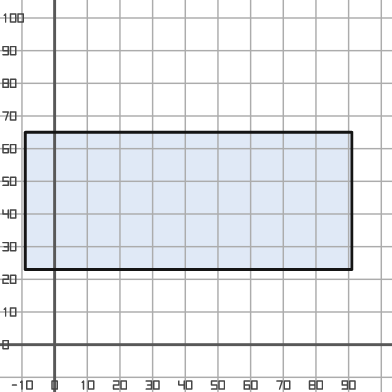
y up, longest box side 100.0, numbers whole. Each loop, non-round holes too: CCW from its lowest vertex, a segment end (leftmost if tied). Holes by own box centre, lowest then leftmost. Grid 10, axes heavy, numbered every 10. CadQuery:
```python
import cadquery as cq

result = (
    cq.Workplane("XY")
    .moveTo(-9.0, 23.0)
    .lineTo(91.0, 23.0)
    .lineTo(91.0, 65.0)
    .lineTo(-9.0, 65.0)
    .close()
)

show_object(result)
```